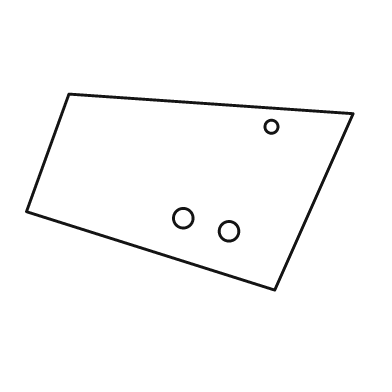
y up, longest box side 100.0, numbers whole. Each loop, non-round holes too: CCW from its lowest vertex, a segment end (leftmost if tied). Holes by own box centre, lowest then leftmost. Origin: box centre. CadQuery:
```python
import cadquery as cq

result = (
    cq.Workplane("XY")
    .moveTo(26.0, -30.0)
    .lineTo(50.0, 24.0)
    .lineTo(-37.0, 30.0)
    .lineTo(-50.0, -6.0)
    .close()
    .moveTo(12.0, -12.0)
    .circle(3.0)
    .moveTo(-2.0, -8.0)
    .circle(3.0)
    .moveTo(25.0, 20.0)
    .circle(2.0)
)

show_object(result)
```